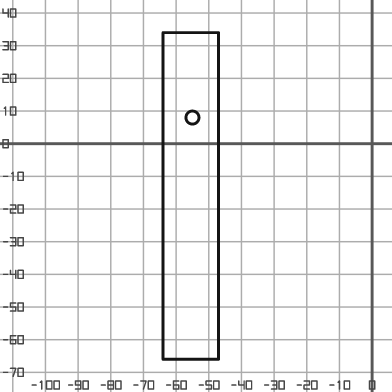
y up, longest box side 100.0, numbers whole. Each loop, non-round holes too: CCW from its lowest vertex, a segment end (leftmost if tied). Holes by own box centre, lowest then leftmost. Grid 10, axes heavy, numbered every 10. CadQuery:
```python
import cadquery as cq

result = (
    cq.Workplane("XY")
    .moveTo(-64.0, -66.0)
    .lineTo(-47.0, -66.0)
    .lineTo(-47.0, 34.0)
    .lineTo(-64.0, 34.0)
    .close()
    .moveTo(-55.0, 8.0)
    .circle(2.0)
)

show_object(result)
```